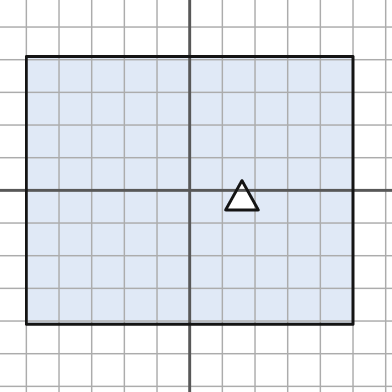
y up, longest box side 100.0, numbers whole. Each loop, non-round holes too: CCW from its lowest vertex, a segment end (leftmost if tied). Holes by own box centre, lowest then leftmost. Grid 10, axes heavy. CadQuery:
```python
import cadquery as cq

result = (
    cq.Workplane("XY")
    .moveTo(-50.0, -41.0)
    .lineTo(50.0, -41.0)
    .lineTo(50.0, 41.0)
    .lineTo(-50.0, 41.0)
    .close()
    .moveTo(11.0, -6.0)
    .lineTo(21.0, -6.0)
    .lineTo(16.0, 3.0)
    .close()
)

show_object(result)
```